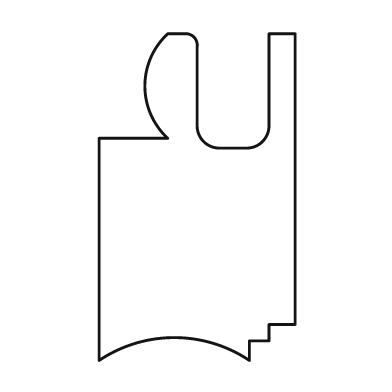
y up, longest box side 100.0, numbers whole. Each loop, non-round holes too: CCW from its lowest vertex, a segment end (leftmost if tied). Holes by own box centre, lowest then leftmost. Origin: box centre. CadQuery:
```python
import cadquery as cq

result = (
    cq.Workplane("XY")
    .moveTo(-30.0, -50.0)
    .threePointArc((-7.0, -43.0), (16.0, -50.0))
    .lineTo(16.0, -44.0)
    .lineTo(22.0, -44.0)
    .lineTo(22.0, -39.0)
    .lineTo(30.0, -39.0)
    .lineTo(30.0, 50.0)
    .lineTo(22.0, 50.0)
    .lineTo(22.0, 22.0)
    .threePointArc((20.0, 17.0), (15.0, 15.0))
    .lineTo(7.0, 15.0)
    .threePointArc((2.0, 17.0), (0.0, 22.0))
    .lineTo(0.0, 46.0)
    .threePointArc((-1.0, 49.0), (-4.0, 50.0))
    .lineTo(-9.0, 50.0)
    .threePointArc((-16.0, 34.0), (-9.0, 18.0))
    .lineTo(-30.0, 18.0)
    .close()
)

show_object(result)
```